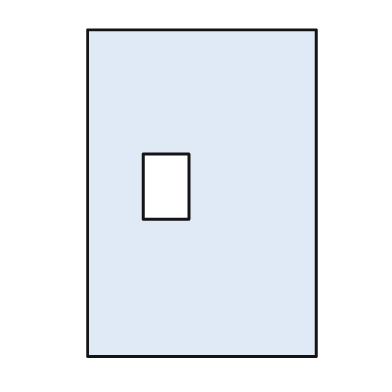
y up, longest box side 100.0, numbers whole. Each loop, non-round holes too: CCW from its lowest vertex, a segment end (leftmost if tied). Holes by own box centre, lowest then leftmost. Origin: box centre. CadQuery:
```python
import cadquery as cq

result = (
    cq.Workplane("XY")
    .moveTo(-35.0, -50.0)
    .lineTo(35.0, -50.0)
    .lineTo(35.0, 50.0)
    .lineTo(-35.0, 50.0)
    .close()
    .moveTo(-18.0, -8.0)
    .lineTo(-4.0, -8.0)
    .lineTo(-4.0, 12.0)
    .lineTo(-18.0, 12.0)
    .close()
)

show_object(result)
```